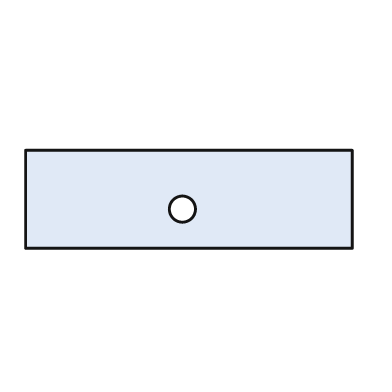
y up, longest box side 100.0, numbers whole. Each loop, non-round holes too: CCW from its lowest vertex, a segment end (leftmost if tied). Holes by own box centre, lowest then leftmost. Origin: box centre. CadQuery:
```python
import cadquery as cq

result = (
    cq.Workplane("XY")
    .moveTo(-50.0, -15.0)
    .lineTo(50.0, -15.0)
    .lineTo(50.0, 15.0)
    .lineTo(-50.0, 15.0)
    .close()
    .moveTo(-2.0, -3.0)
    .circle(4.0)
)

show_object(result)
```